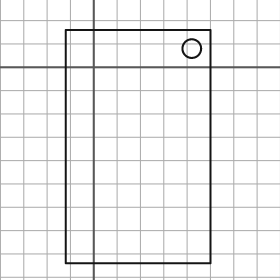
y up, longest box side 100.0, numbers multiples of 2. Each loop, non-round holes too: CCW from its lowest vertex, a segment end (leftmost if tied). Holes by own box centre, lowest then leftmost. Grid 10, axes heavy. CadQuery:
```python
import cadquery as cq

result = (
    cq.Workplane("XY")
    .moveTo(-12.0, -84.0)
    .lineTo(50.0, -84.0)
    .lineTo(50.0, 16.0)
    .lineTo(-12.0, 16.0)
    .close()
    .moveTo(42.0, 8.0)
    .circle(4.0)
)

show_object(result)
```